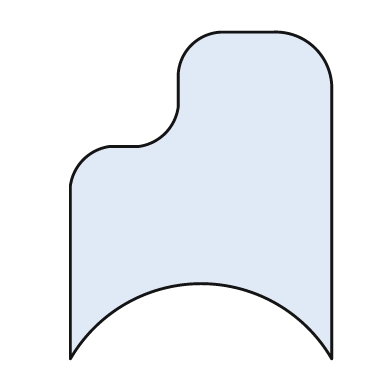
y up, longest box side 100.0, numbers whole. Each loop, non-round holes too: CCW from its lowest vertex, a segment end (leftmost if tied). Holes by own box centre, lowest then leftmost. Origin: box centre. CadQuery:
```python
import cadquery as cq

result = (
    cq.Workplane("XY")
    .moveTo(-40.0, -50.0)
    .threePointArc((0.0, -27.0), (40.0, -50.0))
    .lineTo(40.0, 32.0)
    .threePointArc((35.0, 45.0), (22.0, 50.0))
    .lineTo(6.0, 50.0)
    .threePointArc((-3.0, 46.0), (-7.0, 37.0))
    .lineTo(-7.0, 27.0)
    .threePointArc((-11.0, 19.0), (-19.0, 15.0))
    .lineTo(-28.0, 15.0)
    .threePointArc((-36.0, 11.0), (-40.0, 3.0))
    .close()
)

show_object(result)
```